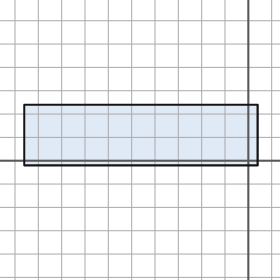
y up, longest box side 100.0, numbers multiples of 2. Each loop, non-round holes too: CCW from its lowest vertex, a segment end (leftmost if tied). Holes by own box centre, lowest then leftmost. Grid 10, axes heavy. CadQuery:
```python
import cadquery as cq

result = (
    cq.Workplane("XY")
    .moveTo(-96.0, -2.0)
    .lineTo(4.0, -2.0)
    .lineTo(4.0, 24.0)
    .lineTo(-96.0, 24.0)
    .close()
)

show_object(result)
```